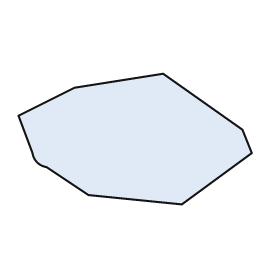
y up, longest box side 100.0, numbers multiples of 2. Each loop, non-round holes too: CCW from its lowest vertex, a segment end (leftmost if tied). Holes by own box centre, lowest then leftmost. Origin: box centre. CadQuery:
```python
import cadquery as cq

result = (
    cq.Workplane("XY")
    .moveTo(20.0, -28.0)
    .lineTo(50.0, -6.0)
    .lineTo(46.0, 4.0)
    .lineTo(12.0, 28.0)
    .lineTo(-26.0, 22.0)
    .lineTo(-50.0, 10.0)
    .lineTo(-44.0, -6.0)
    .threePointArc((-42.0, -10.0), (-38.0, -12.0))
    .lineTo(-20.0, -24.0)
    .close()
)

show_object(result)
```